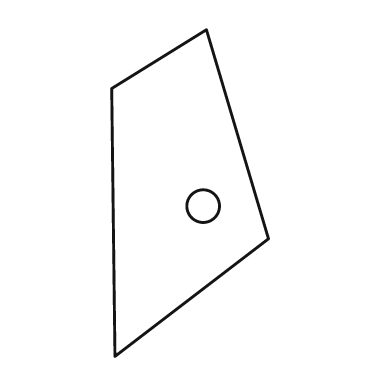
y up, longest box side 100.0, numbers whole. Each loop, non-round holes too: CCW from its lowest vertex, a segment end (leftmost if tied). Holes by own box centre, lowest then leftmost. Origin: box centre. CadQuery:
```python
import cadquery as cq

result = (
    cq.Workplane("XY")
    .moveTo(-23.0, -50.0)
    .lineTo(24.0, -14.0)
    .lineTo(5.0, 50.0)
    .lineTo(-24.0, 32.0)
    .close()
    .moveTo(4.0, -4.0)
    .circle(5.0)
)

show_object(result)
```